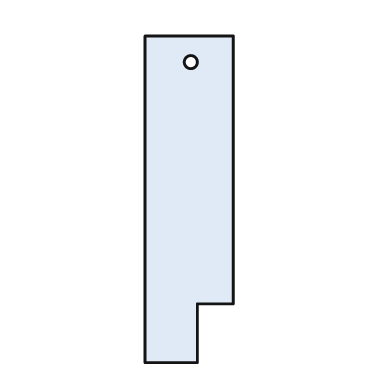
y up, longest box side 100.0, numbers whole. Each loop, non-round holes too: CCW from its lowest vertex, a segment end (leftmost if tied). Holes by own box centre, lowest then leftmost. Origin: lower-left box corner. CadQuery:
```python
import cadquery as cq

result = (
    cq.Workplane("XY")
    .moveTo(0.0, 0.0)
    .lineTo(16.0, 0.0)
    .lineTo(16.0, 18.0)
    .lineTo(27.0, 18.0)
    .lineTo(27.0, 100.0)
    .lineTo(0.0, 100.0)
    .close()
    .moveTo(14.0, 92.0)
    .circle(2.0)
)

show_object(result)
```